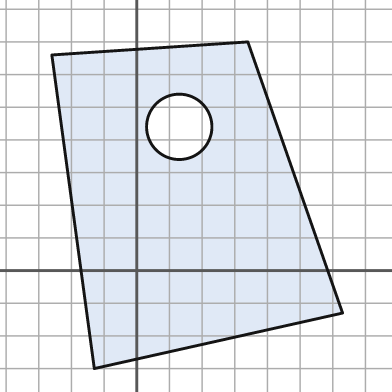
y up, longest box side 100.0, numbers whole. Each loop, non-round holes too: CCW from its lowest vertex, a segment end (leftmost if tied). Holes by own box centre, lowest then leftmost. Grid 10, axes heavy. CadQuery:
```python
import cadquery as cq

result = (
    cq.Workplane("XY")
    .moveTo(-13.0, -30.0)
    .lineTo(63.0, -13.0)
    .lineTo(34.0, 70.0)
    .lineTo(-26.0, 66.0)
    .close()
    .moveTo(13.0, 44.0)
    .circle(10.0)
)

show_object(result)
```